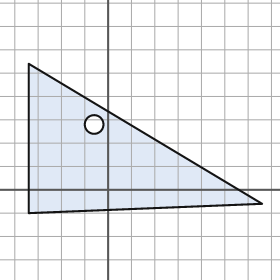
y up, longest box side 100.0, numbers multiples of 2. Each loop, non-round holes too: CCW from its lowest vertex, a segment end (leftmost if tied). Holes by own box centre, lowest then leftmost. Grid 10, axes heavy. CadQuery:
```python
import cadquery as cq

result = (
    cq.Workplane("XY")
    .moveTo(-34.0, -10.0)
    .lineTo(66.0, -6.0)
    .lineTo(-34.0, 54.0)
    .close()
    .moveTo(-6.0, 28.0)
    .circle(4.0)
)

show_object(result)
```